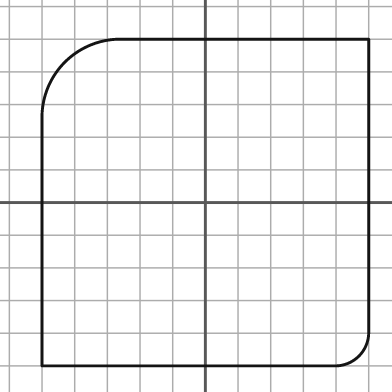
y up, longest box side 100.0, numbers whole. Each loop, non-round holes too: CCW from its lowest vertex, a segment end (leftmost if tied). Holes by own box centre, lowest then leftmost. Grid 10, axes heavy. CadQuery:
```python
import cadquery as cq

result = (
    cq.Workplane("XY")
    .moveTo(-50.0, -50.0)
    .lineTo(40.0, -50.0)
    .threePointArc((47.0, -47.0), (50.0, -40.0))
    .lineTo(50.0, 50.0)
    .lineTo(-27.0, 50.0)
    .threePointArc((-43.0, 43.0), (-50.0, 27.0))
    .close()
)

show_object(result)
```